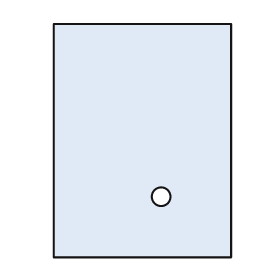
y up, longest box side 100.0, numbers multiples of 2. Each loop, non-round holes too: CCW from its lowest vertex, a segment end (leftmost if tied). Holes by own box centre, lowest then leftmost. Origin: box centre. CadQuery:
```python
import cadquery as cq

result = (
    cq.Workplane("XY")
    .moveTo(-38.0, -50.0)
    .lineTo(38.0, -50.0)
    .lineTo(38.0, 50.0)
    .lineTo(-38.0, 50.0)
    .close()
    .moveTo(8.0, -24.0)
    .circle(4.0)
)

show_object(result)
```